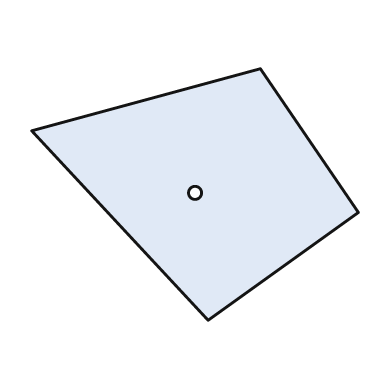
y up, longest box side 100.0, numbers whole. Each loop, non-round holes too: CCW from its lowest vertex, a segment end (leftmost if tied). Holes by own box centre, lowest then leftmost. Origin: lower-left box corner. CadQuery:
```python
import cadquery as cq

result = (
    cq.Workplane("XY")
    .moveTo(54.0, 0.0)
    .lineTo(100.0, 33.0)
    .lineTo(70.0, 77.0)
    .lineTo(0.0, 58.0)
    .close()
    .moveTo(50.0, 39.0)
    .circle(2.0)
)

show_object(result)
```